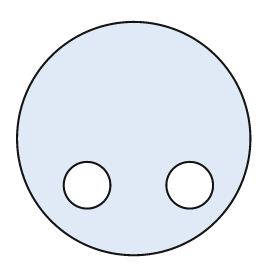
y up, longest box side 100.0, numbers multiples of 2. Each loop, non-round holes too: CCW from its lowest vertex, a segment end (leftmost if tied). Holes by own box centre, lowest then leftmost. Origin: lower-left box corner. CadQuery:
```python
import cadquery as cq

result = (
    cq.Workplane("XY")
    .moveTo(50.0, 50.0)
    .circle(50.0)
    .moveTo(30.0, 30.0)
    .circle(10.0)
    .moveTo(74.0, 30.0)
    .circle(10.0)
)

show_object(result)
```